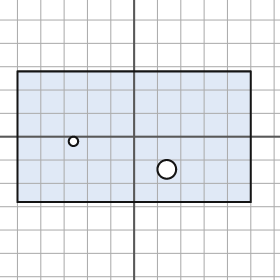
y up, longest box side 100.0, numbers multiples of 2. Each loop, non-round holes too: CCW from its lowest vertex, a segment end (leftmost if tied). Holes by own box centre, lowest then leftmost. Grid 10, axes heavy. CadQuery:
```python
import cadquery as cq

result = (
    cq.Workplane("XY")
    .moveTo(-50.0, -28.0)
    .lineTo(50.0, -28.0)
    .lineTo(50.0, 28.0)
    .lineTo(-50.0, 28.0)
    .close()
    .moveTo(14.0, -14.0)
    .circle(4.0)
    .moveTo(-26.0, -2.0)
    .circle(2.0)
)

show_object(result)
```